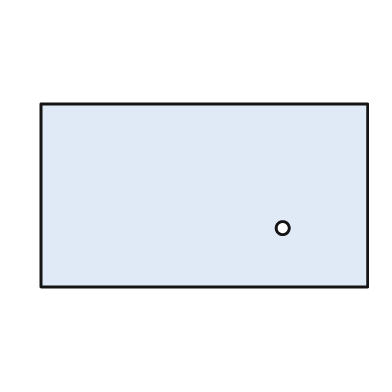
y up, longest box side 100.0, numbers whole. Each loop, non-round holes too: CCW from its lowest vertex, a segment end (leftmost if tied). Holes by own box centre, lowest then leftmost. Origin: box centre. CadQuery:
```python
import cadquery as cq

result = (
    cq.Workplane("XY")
    .moveTo(-50.0, -28.0)
    .lineTo(50.0, -28.0)
    .lineTo(50.0, 28.0)
    .lineTo(-50.0, 28.0)
    .close()
    .moveTo(24.0, -10.0)
    .circle(2.0)
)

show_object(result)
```